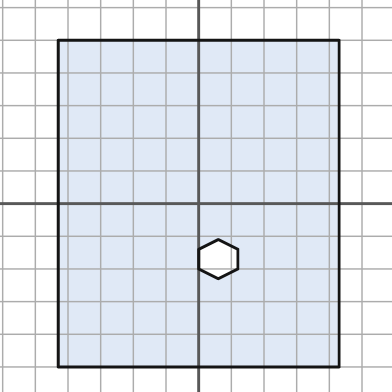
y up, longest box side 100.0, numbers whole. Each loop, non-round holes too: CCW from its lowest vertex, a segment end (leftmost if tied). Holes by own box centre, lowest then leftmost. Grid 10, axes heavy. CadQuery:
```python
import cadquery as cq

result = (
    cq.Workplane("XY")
    .moveTo(-43.0, -50.0)
    .lineTo(43.0, -50.0)
    .lineTo(43.0, 50.0)
    .lineTo(-43.0, 50.0)
    .close()
    .moveTo(6.0, -23.0)
    .lineTo(12.0, -20.0)
    .lineTo(12.0, -14.0)
    .lineTo(6.0, -11.0)
    .lineTo(0.0, -14.0)
    .lineTo(0.0, -20.0)
    .close()
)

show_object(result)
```